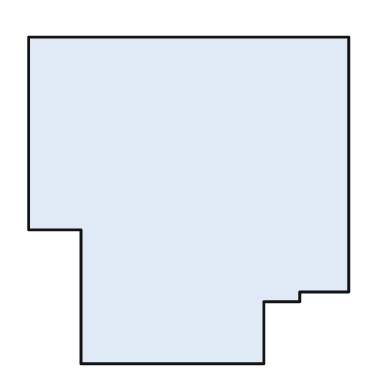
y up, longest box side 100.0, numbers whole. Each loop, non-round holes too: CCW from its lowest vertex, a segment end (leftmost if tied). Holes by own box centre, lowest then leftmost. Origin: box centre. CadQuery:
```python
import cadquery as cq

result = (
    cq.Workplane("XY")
    .moveTo(-33.0, -50.0)
    .lineTo(23.0, -50.0)
    .lineTo(23.0, -31.0)
    .lineTo(34.0, -31.0)
    .lineTo(34.0, -28.0)
    .lineTo(49.0, -28.0)
    .lineTo(49.0, 50.0)
    .lineTo(-49.0, 50.0)
    .lineTo(-49.0, -9.0)
    .lineTo(-33.0, -9.0)
    .close()
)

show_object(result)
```